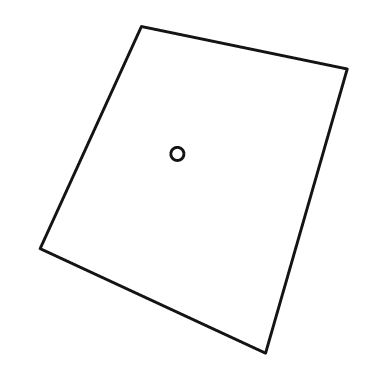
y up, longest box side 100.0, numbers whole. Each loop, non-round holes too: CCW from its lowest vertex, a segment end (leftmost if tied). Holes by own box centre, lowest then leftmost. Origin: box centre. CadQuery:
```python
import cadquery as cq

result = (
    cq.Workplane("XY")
    .moveTo(22.0, -50.0)
    .lineTo(47.0, 37.0)
    .lineTo(-16.0, 50.0)
    .lineTo(-47.0, -18.0)
    .close()
    .moveTo(-5.0, 11.0)
    .circle(2.0)
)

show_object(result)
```